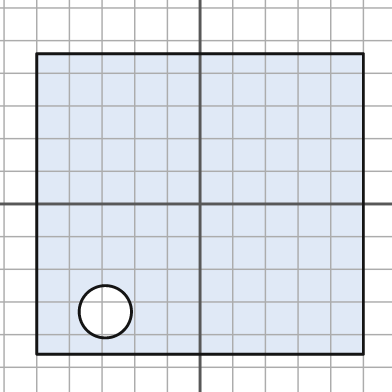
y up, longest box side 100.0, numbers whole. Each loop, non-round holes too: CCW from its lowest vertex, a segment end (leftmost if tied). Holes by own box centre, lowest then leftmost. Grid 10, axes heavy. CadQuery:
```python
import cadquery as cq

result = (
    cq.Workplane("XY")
    .moveTo(-50.0, -46.0)
    .lineTo(50.0, -46.0)
    .lineTo(50.0, 46.0)
    .lineTo(-50.0, 46.0)
    .close()
    .moveTo(-29.0, -33.0)
    .circle(8.0)
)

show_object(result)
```